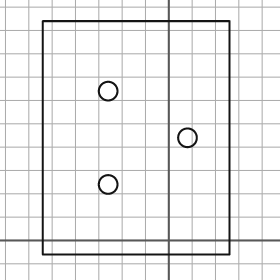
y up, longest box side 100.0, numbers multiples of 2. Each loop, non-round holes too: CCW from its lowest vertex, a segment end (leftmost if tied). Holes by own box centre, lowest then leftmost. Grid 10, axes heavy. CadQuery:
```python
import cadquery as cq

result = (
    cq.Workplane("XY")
    .moveTo(-54.0, -6.0)
    .lineTo(26.0, -6.0)
    .lineTo(26.0, 94.0)
    .lineTo(-54.0, 94.0)
    .close()
    .moveTo(-26.0, 24.0)
    .circle(4.0)
    .moveTo(8.0, 44.0)
    .circle(4.0)
    .moveTo(-26.0, 64.0)
    .circle(4.0)
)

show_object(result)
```